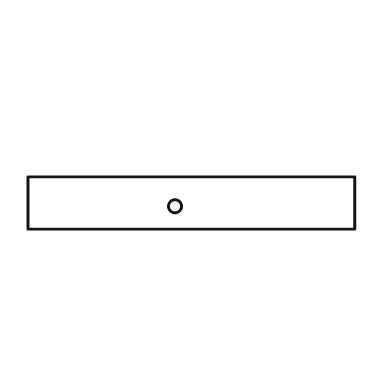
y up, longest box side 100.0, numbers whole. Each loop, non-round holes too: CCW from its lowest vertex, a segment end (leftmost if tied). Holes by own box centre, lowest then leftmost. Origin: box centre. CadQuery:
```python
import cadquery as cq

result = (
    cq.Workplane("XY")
    .moveTo(-50.0, -8.0)
    .lineTo(50.0, -8.0)
    .lineTo(50.0, 8.0)
    .lineTo(-50.0, 8.0)
    .close()
    .moveTo(-5.0, -1.0)
    .circle(2.0)
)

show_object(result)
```